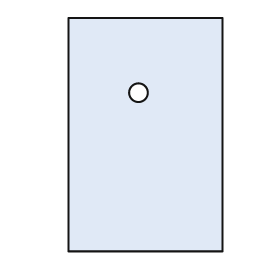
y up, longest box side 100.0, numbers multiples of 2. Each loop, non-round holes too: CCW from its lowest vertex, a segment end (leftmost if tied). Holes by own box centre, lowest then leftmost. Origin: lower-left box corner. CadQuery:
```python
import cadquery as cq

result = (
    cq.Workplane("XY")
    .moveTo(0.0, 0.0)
    .lineTo(66.0, 0.0)
    .lineTo(66.0, 100.0)
    .lineTo(0.0, 100.0)
    .close()
    .moveTo(30.0, 68.0)
    .circle(4.0)
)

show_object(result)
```